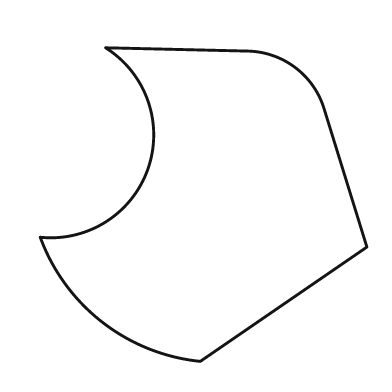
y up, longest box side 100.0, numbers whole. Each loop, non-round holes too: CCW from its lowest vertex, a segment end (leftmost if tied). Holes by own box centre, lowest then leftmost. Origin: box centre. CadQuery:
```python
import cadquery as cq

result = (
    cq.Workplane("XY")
    .moveTo(-1.0, -48.0)
    .lineTo(50.0, -13.0)
    .lineTo(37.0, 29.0)
    .threePointArc((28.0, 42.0), (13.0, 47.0))
    .lineTo(-30.0, 48.0)
    .threePointArc((-17.0, 11.0), (-50.0, -10.0))
    .threePointArc((-31.0, -36.0), (-1.0, -48.0))
    .close()
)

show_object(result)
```